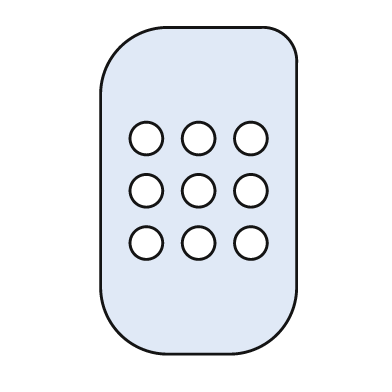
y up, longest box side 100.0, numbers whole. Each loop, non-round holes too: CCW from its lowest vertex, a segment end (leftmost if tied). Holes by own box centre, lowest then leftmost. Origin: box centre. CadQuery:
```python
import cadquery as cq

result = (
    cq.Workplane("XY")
    .moveTo(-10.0, -50.0)
    .lineTo(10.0, -50.0)
    .threePointArc((24.0, -44.0), (30.0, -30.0))
    .lineTo(30.0, 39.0)
    .threePointArc((27.0, 47.0), (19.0, 50.0))
    .lineTo(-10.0, 50.0)
    .threePointArc((-24.0, 44.0), (-30.0, 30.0))
    .lineTo(-30.0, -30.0)
    .threePointArc((-24.0, -44.0), (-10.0, -50.0))
    .close()
    .moveTo(-16.0, -16.0)
    .circle(5.0)
    .moveTo(0.0, -16.0)
    .circle(5.0)
    .moveTo(16.0, -16.0)
    .circle(5.0)
    .moveTo(-16.0, 0.0)
    .circle(5.0)
    .moveTo(0.0, 0.0)
    .circle(5.0)
    .moveTo(16.0, 0.0)
    .circle(5.0)
    .moveTo(-16.0, 16.0)
    .circle(5.0)
    .moveTo(0.0, 16.0)
    .circle(5.0)
    .moveTo(16.0, 16.0)
    .circle(5.0)
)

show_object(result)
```